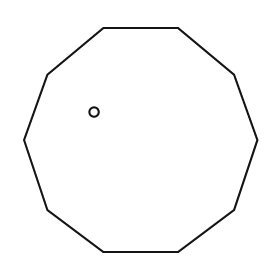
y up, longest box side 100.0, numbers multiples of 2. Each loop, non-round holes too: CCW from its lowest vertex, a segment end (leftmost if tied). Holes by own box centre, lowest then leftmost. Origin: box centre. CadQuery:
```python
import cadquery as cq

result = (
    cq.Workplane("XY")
    .moveTo(-16.0, -48.0)
    .lineTo(16.0, -48.0)
    .lineTo(40.0, -30.0)
    .lineTo(50.0, 0.0)
    .lineTo(40.0, 28.0)
    .lineTo(16.0, 48.0)
    .lineTo(-16.0, 48.0)
    .lineTo(-40.0, 28.0)
    .lineTo(-50.0, 0.0)
    .lineTo(-40.0, -30.0)
    .close()
    .moveTo(-20.0, 12.0)
    .circle(2.0)
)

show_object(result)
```